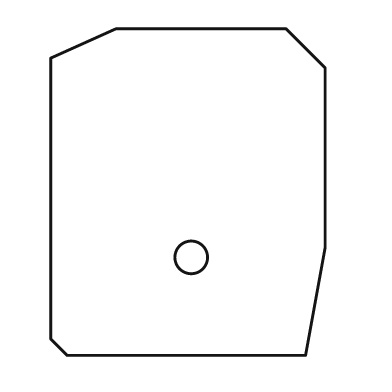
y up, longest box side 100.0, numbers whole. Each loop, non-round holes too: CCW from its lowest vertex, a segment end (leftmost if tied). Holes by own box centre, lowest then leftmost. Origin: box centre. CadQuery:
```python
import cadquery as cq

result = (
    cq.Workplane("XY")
    .moveTo(-37.0, -50.0)
    .lineTo(36.0, -50.0)
    .lineTo(42.0, -17.0)
    .lineTo(42.0, 38.0)
    .lineTo(30.0, 50.0)
    .lineTo(-22.0, 50.0)
    .lineTo(-42.0, 41.0)
    .lineTo(-42.0, -45.0)
    .close()
    .moveTo(1.0, -20.0)
    .circle(5.0)
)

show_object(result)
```